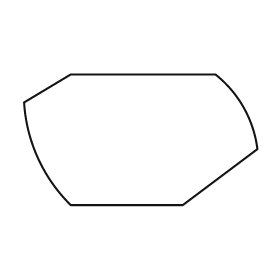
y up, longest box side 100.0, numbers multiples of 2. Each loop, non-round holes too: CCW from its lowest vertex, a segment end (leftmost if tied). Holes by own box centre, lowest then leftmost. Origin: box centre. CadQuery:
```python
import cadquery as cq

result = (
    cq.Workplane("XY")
    .moveTo(-30.0, -28.0)
    .lineTo(18.0, -28.0)
    .lineTo(50.0, -4.0)
    .threePointArc((44.0, 14.0), (32.0, 28.0))
    .lineTo(-30.0, 28.0)
    .lineTo(-50.0, 16.0)
    .threePointArc((-44.0, -8.0), (-30.0, -28.0))
    .close()
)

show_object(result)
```